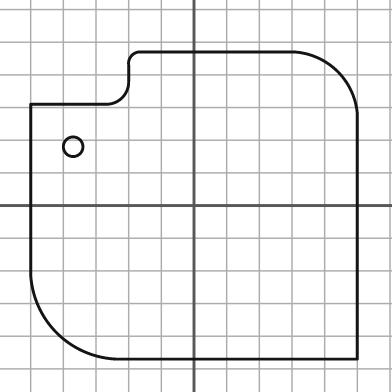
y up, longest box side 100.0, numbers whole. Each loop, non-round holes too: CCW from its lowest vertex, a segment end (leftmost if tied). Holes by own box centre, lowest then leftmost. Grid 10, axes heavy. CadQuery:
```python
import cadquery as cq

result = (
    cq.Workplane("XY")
    .moveTo(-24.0, -47.0)
    .lineTo(50.0, -47.0)
    .lineTo(50.0, 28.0)
    .threePointArc((44.0, 41.0), (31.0, 47.0))
    .lineTo(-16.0, 47.0)
    .threePointArc((-19.0, 46.0), (-20.0, 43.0))
    .lineTo(-20.0, 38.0)
    .threePointArc((-22.0, 33.0), (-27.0, 31.0))
    .lineTo(-50.0, 31.0)
    .lineTo(-50.0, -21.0)
    .threePointArc((-42.0, -39.0), (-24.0, -47.0))
    .close()
    .moveTo(-37.0, 18.0)
    .circle(3.0)
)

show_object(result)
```